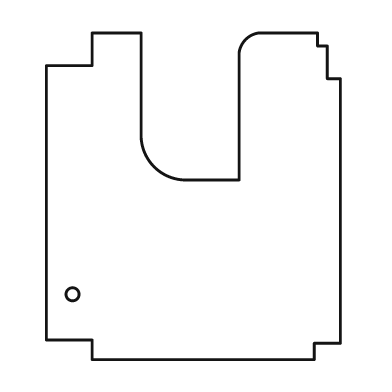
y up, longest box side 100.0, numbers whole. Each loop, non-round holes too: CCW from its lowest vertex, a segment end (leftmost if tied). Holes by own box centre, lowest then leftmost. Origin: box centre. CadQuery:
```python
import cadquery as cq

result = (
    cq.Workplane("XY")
    .moveTo(-31.0, -50.0)
    .lineTo(37.0, -50.0)
    .lineTo(37.0, -45.0)
    .lineTo(45.0, -45.0)
    .lineTo(45.0, 36.0)
    .lineTo(41.0, 36.0)
    .lineTo(41.0, 46.0)
    .lineTo(38.0, 46.0)
    .lineTo(38.0, 50.0)
    .lineTo(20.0, 50.0)
    .threePointArc((16.0, 48.0), (14.0, 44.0))
    .lineTo(14.0, 5.0)
    .lineTo(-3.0, 5.0)
    .threePointArc((-12.0, 9.0), (-16.0, 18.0))
    .lineTo(-16.0, 50.0)
    .lineTo(-31.0, 50.0)
    .lineTo(-31.0, 40.0)
    .lineTo(-45.0, 40.0)
    .lineTo(-45.0, -44.0)
    .lineTo(-31.0, -44.0)
    .close()
    .moveTo(-37.0, -30.0)
    .circle(2.0)
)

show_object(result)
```